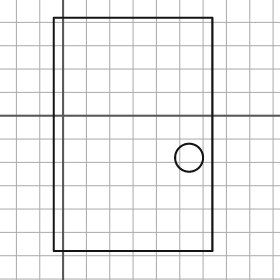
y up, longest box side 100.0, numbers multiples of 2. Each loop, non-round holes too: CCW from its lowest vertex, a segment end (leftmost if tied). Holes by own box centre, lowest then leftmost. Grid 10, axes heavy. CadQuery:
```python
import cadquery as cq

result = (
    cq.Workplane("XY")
    .moveTo(-4.0, -58.0)
    .lineTo(64.0, -58.0)
    .lineTo(64.0, 42.0)
    .lineTo(-4.0, 42.0)
    .close()
    .moveTo(54.0, -18.0)
    .circle(6.0)
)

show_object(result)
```